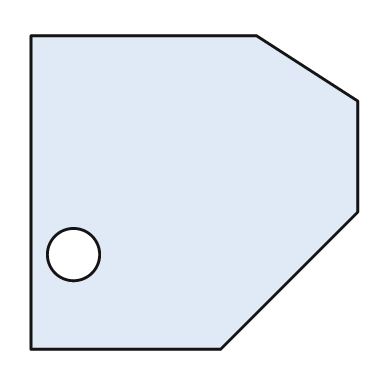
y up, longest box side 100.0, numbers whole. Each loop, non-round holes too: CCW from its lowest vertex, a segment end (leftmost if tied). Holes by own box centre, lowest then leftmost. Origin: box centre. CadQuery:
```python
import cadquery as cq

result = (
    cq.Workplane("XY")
    .moveTo(-50.0, -48.0)
    .lineTo(8.0, -48.0)
    .lineTo(50.0, -6.0)
    .lineTo(50.0, 28.0)
    .lineTo(19.0, 48.0)
    .lineTo(-50.0, 48.0)
    .close()
    .moveTo(-37.0, -19.0)
    .circle(8.0)
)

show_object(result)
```